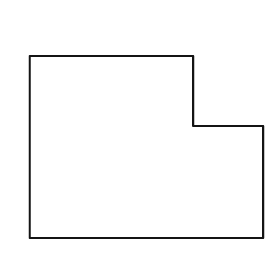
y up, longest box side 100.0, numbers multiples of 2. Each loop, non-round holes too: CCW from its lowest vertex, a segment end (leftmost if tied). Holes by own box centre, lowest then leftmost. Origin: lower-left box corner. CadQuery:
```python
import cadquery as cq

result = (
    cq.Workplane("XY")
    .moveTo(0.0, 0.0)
    .lineTo(100.0, 0.0)
    .lineTo(100.0, 48.0)
    .lineTo(70.0, 48.0)
    .lineTo(70.0, 78.0)
    .lineTo(0.0, 78.0)
    .close()
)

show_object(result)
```